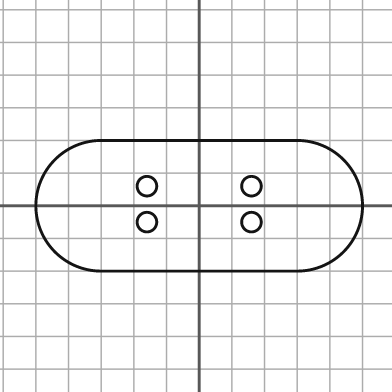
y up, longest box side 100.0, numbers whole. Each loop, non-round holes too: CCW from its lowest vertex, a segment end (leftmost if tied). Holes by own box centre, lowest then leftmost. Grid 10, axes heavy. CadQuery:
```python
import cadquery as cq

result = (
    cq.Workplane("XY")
    .moveTo(-30.0, -20.0)
    .lineTo(30.0, -20.0)
    .threePointArc((50.0, 0.0), (30.0, 20.0))
    .lineTo(-30.0, 20.0)
    .threePointArc((-50.0, 0.0), (-30.0, -20.0))
    .close()
    .moveTo(-16.0, -5.0)
    .circle(3.0)
    .moveTo(16.0, -5.0)
    .circle(3.0)
    .moveTo(-16.0, 6.0)
    .circle(3.0)
    .moveTo(16.0, 6.0)
    .circle(3.0)
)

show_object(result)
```